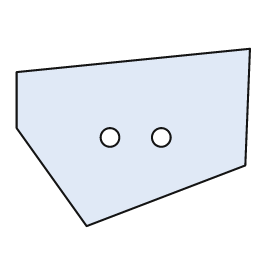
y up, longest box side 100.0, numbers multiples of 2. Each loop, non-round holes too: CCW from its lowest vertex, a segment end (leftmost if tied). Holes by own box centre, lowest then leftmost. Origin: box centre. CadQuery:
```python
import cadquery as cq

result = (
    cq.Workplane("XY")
    .moveTo(-20.0, -38.0)
    .lineTo(48.0, -12.0)
    .lineTo(50.0, 38.0)
    .lineTo(-50.0, 28.0)
    .lineTo(-50.0, 4.0)
    .close()
    .moveTo(-10.0, 0.0)
    .circle(4.0)
    .moveTo(12.0, 0.0)
    .circle(4.0)
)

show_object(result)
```